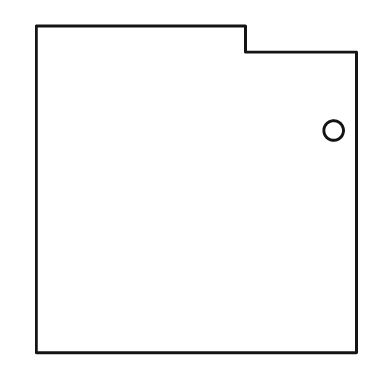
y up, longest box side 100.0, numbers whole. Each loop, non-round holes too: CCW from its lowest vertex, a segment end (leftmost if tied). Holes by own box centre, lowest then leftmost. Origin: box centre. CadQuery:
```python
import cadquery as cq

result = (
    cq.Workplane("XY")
    .moveTo(-49.0, -50.0)
    .lineTo(49.0, -50.0)
    .lineTo(49.0, 42.0)
    .lineTo(15.0, 42.0)
    .lineTo(15.0, 50.0)
    .lineTo(-49.0, 50.0)
    .close()
    .moveTo(42.0, 18.0)
    .circle(3.0)
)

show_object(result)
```